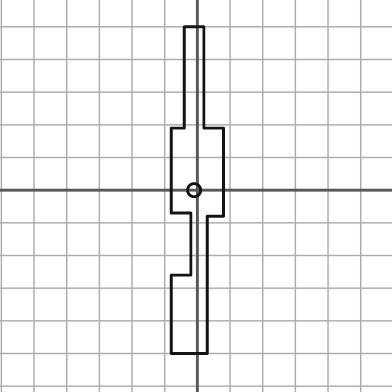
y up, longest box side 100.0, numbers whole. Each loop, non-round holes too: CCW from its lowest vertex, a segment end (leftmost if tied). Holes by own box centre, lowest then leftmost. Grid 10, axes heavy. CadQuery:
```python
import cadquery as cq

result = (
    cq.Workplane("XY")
    .moveTo(-8.0, -50.0)
    .lineTo(3.0, -50.0)
    .lineTo(3.0, -8.0)
    .lineTo(8.0, -8.0)
    .lineTo(8.0, 19.0)
    .lineTo(2.0, 19.0)
    .lineTo(2.0, 50.0)
    .lineTo(-4.0, 50.0)
    .lineTo(-4.0, 19.0)
    .lineTo(-8.0, 19.0)
    .lineTo(-8.0, -7.0)
    .lineTo(-2.0, -7.0)
    .lineTo(-2.0, -26.0)
    .lineTo(-8.0, -26.0)
    .close()
    .moveTo(-1.0, 0.0)
    .circle(2.0)
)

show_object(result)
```